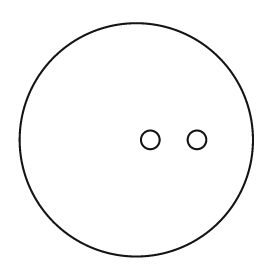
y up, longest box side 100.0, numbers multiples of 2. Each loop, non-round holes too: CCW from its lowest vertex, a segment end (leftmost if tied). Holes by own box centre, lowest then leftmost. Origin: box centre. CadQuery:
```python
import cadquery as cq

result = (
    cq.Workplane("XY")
    .moveTo(0.0, 0.0)
    .circle(50.0)
    .moveTo(6.0, 0.0)
    .circle(4.0)
    .moveTo(26.0, 0.0)
    .circle(4.0)
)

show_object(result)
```